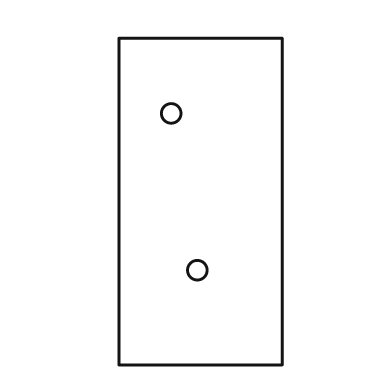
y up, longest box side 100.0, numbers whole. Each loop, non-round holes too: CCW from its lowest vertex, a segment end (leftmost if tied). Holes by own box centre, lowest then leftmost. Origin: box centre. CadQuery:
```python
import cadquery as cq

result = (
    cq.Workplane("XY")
    .moveTo(-25.0, -50.0)
    .lineTo(25.0, -50.0)
    .lineTo(25.0, 50.0)
    .lineTo(-25.0, 50.0)
    .close()
    .moveTo(-1.0, -21.0)
    .circle(3.0)
    .moveTo(-9.0, 27.0)
    .circle(3.0)
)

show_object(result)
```